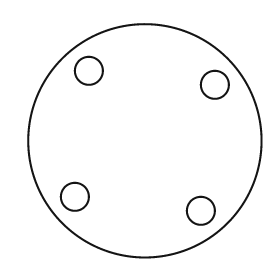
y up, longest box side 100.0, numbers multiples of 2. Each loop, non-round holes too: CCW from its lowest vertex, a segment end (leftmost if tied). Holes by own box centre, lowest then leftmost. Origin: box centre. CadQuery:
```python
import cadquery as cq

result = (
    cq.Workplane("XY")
    .moveTo(0.0, 0.0)
    .circle(50.0)
    .moveTo(24.0, -30.0)
    .circle(6.0)
    .moveTo(-30.0, -24.0)
    .circle(6.0)
    .moveTo(30.0, 24.0)
    .circle(6.0)
    .moveTo(-24.0, 30.0)
    .circle(6.0)
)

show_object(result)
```